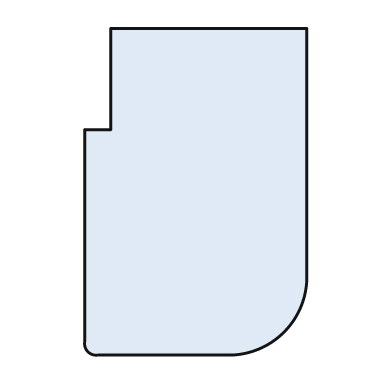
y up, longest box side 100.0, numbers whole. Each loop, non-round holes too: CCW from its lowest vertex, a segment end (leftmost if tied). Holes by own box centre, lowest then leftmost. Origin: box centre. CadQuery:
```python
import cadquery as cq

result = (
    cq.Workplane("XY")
    .moveTo(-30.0, -50.0)
    .lineTo(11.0, -50.0)
    .threePointArc((27.0, -43.0), (34.0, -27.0))
    .lineTo(34.0, 50.0)
    .lineTo(-26.0, 50.0)
    .lineTo(-26.0, 19.0)
    .lineTo(-34.0, 19.0)
    .lineTo(-34.0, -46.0)
    .threePointArc((-33.0, -49.0), (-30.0, -50.0))
    .close()
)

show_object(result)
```